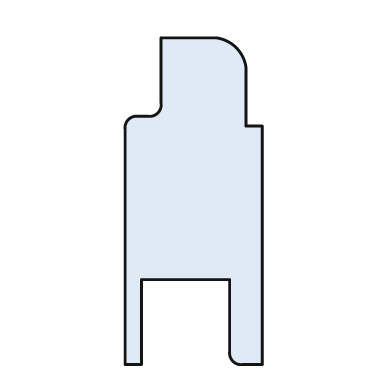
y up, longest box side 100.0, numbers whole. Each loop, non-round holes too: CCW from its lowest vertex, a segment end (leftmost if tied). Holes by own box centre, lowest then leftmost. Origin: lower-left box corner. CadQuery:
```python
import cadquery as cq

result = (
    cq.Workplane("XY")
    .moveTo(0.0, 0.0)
    .lineTo(5.0, 0.0)
    .lineTo(5.0, 26.0)
    .lineTo(32.0, 26.0)
    .lineTo(32.0, 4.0)
    .threePointArc((33.0, 1.0), (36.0, 0.0))
    .lineTo(42.0, 0.0)
    .lineTo(42.0, 73.0)
    .lineTo(37.0, 73.0)
    .lineTo(37.0, 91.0)
    .threePointArc((34.0, 97.0), (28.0, 100.0))
    .lineTo(11.0, 100.0)
    .lineTo(11.0, 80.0)
    .threePointArc((10.0, 77.0), (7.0, 76.0))
    .lineTo(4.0, 76.0)
    .threePointArc((1.0, 75.0), (0.0, 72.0))
    .close()
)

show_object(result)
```